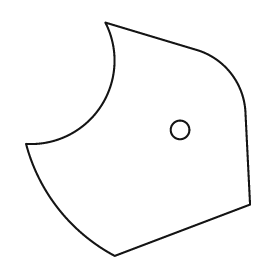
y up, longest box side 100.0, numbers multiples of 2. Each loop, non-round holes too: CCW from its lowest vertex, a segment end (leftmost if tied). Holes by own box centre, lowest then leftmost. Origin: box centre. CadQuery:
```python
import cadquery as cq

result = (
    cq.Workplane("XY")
    .moveTo(-10.0, -50.0)
    .lineTo(48.0, -28.0)
    .lineTo(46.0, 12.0)
    .threePointArc((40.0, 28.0), (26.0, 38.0))
    .lineTo(-14.0, 50.0)
    .threePointArc((-16.0, 14.0), (-48.0, -2.0))
    .threePointArc((-34.0, -30.0), (-10.0, -50.0))
    .close()
    .moveTo(18.0, 4.0)
    .circle(4.0)
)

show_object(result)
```